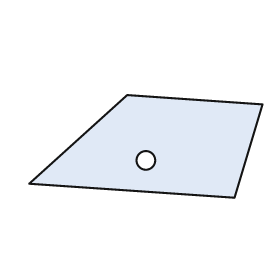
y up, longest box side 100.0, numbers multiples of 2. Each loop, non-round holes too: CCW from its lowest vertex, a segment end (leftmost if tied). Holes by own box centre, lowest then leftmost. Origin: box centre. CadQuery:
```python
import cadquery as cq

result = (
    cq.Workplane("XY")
    .moveTo(38.0, -22.0)
    .lineTo(50.0, 18.0)
    .lineTo(-8.0, 22.0)
    .lineTo(-50.0, -16.0)
    .close()
    .moveTo(0.0, -6.0)
    .circle(4.0)
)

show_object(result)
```